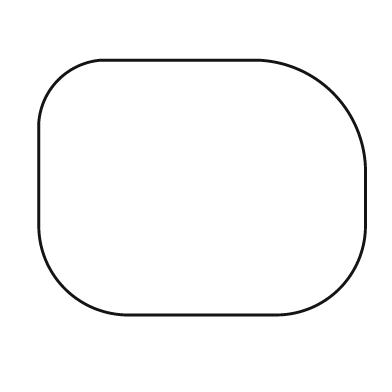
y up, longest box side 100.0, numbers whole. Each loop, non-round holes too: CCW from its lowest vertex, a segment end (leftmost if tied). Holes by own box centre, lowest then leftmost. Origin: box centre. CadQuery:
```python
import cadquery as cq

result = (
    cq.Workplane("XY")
    .moveTo(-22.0, -39.0)
    .lineTo(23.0, -39.0)
    .threePointArc((42.0, -31.0), (50.0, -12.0))
    .lineTo(50.0, 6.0)
    .threePointArc((40.0, 29.0), (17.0, 39.0))
    .lineTo(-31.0, 39.0)
    .threePointArc((-44.0, 33.0), (-50.0, 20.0))
    .lineTo(-50.0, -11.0)
    .threePointArc((-42.0, -31.0), (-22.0, -39.0))
    .close()
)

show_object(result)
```